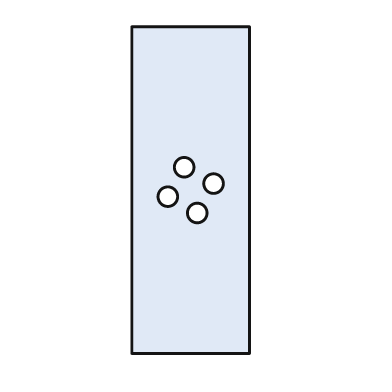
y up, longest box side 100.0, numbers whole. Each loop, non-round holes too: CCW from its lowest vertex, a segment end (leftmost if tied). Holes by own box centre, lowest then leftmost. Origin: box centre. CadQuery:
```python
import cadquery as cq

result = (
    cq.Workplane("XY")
    .moveTo(-18.0, -50.0)
    .lineTo(18.0, -50.0)
    .lineTo(18.0, 50.0)
    .lineTo(-18.0, 50.0)
    .close()
    .moveTo(2.0, -7.0)
    .circle(3.0)
    .moveTo(-7.0, -2.0)
    .circle(3.0)
    .moveTo(7.0, 2.0)
    .circle(3.0)
    .moveTo(-2.0, 7.0)
    .circle(3.0)
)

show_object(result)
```